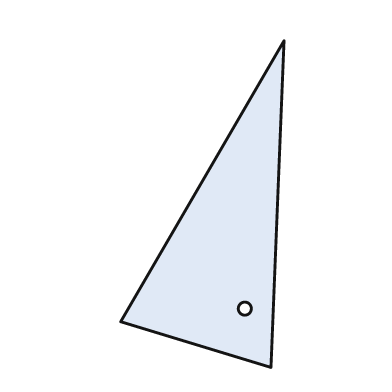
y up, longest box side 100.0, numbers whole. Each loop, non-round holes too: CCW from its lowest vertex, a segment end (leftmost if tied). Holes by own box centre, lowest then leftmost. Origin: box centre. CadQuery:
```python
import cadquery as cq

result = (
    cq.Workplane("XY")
    .moveTo(21.0, -50.0)
    .lineTo(25.0, 50.0)
    .lineTo(-25.0, -36.0)
    .close()
    .moveTo(13.0, -32.0)
    .circle(2.0)
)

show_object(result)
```